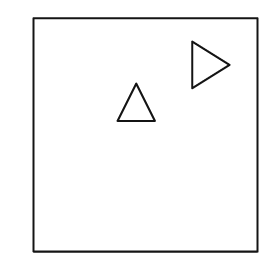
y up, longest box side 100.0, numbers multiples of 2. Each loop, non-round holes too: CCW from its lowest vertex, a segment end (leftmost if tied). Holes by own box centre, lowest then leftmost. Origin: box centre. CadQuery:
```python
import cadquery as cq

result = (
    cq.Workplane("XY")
    .moveTo(-48.0, -50.0)
    .lineTo(48.0, -50.0)
    .lineTo(48.0, 50.0)
    .lineTo(-48.0, 50.0)
    .close()
    .moveTo(-12.0, 6.0)
    .lineTo(4.0, 6.0)
    .lineTo(-4.0, 22.0)
    .close()
    .moveTo(20.0, 20.0)
    .lineTo(36.0, 30.0)
    .lineTo(20.0, 40.0)
    .close()
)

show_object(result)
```